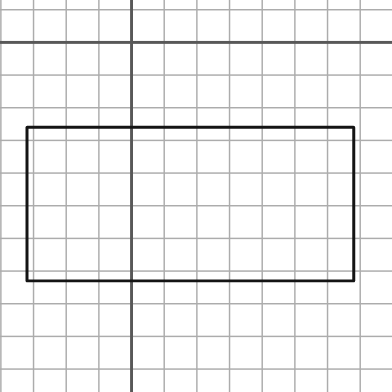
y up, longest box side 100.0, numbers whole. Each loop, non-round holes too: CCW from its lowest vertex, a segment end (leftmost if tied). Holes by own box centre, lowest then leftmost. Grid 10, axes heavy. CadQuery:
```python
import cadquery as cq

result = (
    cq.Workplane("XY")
    .moveTo(-32.0, -73.0)
    .lineTo(68.0, -73.0)
    .lineTo(68.0, -26.0)
    .lineTo(-32.0, -26.0)
    .close()
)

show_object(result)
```